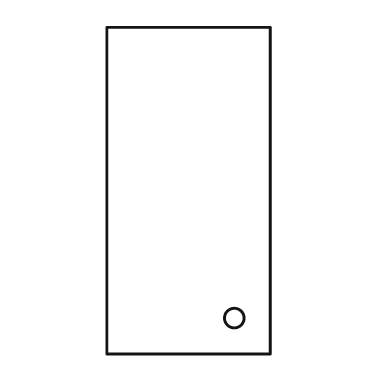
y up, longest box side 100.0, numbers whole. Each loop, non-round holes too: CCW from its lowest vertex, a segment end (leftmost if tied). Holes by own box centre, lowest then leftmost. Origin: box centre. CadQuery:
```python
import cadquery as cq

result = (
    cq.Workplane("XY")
    .moveTo(-25.0, -50.0)
    .lineTo(25.0, -50.0)
    .lineTo(25.0, 50.0)
    .lineTo(-25.0, 50.0)
    .close()
    .moveTo(14.0, -39.0)
    .circle(3.0)
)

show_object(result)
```